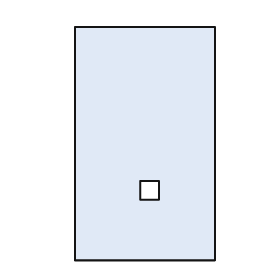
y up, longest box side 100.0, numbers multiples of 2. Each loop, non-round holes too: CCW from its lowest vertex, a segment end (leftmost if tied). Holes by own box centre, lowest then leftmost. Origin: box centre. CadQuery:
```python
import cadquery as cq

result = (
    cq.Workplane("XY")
    .moveTo(-30.0, -50.0)
    .lineTo(30.0, -50.0)
    .lineTo(30.0, 50.0)
    .lineTo(-30.0, 50.0)
    .close()
    .moveTo(-2.0, -24.0)
    .lineTo(6.0, -24.0)
    .lineTo(6.0, -16.0)
    .lineTo(-2.0, -16.0)
    .close()
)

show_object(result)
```